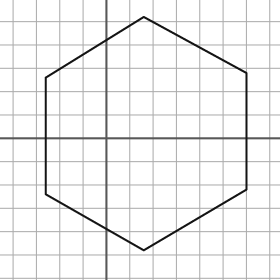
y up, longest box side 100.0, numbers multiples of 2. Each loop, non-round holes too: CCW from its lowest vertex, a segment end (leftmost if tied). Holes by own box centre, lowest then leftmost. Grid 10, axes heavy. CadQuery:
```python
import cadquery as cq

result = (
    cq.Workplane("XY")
    .moveTo(16.0, -48.0)
    .lineTo(60.0, -22.0)
    .lineTo(60.0, 28.0)
    .lineTo(16.0, 52.0)
    .lineTo(-26.0, 26.0)
    .lineTo(-26.0, -24.0)
    .close()
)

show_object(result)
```